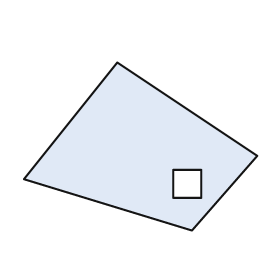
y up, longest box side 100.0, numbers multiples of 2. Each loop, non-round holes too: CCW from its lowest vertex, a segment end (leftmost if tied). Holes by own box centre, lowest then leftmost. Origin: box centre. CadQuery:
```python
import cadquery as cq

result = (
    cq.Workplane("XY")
    .moveTo(22.0, -36.0)
    .lineTo(50.0, -4.0)
    .lineTo(-10.0, 36.0)
    .lineTo(-50.0, -14.0)
    .close()
    .moveTo(14.0, -22.0)
    .lineTo(26.0, -22.0)
    .lineTo(26.0, -10.0)
    .lineTo(14.0, -10.0)
    .close()
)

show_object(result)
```